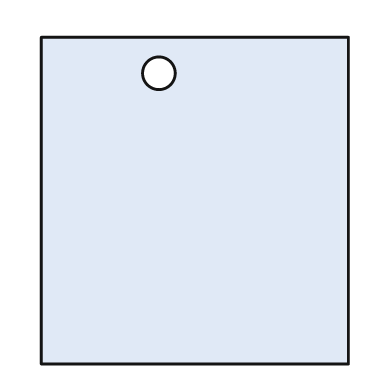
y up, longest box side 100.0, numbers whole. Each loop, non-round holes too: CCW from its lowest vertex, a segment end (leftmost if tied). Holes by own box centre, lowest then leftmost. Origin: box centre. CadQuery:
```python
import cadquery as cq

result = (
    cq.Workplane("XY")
    .moveTo(-47.0, -50.0)
    .lineTo(47.0, -50.0)
    .lineTo(47.0, 50.0)
    .lineTo(-47.0, 50.0)
    .close()
    .moveTo(-11.0, 39.0)
    .circle(5.0)
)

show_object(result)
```